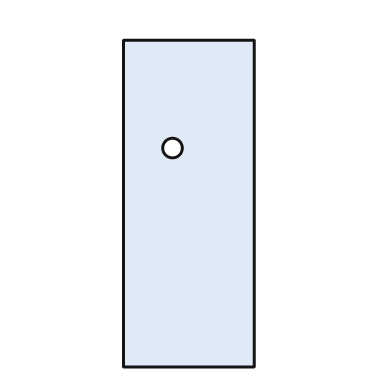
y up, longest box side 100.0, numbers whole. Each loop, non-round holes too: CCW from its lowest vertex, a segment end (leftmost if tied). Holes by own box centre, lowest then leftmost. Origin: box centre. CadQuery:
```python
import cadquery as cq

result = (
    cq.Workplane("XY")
    .moveTo(-20.0, -50.0)
    .lineTo(20.0, -50.0)
    .lineTo(20.0, 50.0)
    .lineTo(-20.0, 50.0)
    .close()
    .moveTo(-5.0, 17.0)
    .circle(3.0)
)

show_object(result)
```